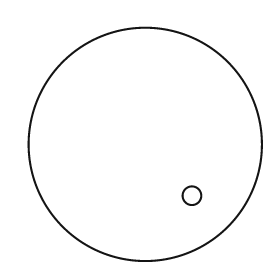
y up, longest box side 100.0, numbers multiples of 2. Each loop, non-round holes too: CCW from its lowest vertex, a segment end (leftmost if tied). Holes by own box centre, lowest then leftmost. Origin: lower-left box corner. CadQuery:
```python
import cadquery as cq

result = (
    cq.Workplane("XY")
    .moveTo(50.0, 50.0)
    .circle(50.0)
    .moveTo(70.0, 28.0)
    .circle(4.0)
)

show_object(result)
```